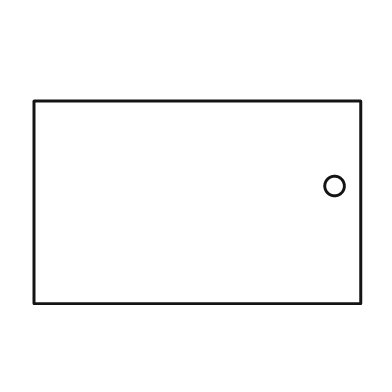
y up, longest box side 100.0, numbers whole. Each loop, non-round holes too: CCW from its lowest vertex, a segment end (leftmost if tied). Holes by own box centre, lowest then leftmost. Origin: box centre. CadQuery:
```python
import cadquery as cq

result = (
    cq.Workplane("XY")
    .moveTo(-50.0, -31.0)
    .lineTo(50.0, -31.0)
    .lineTo(50.0, 31.0)
    .lineTo(-50.0, 31.0)
    .close()
    .moveTo(42.0, 5.0)
    .circle(3.0)
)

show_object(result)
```